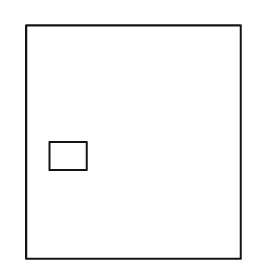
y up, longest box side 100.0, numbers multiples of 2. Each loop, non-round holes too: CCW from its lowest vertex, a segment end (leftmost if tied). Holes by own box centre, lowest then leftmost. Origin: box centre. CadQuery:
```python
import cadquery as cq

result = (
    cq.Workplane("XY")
    .moveTo(-46.0, -50.0)
    .lineTo(46.0, -50.0)
    .lineTo(46.0, 50.0)
    .lineTo(-46.0, 50.0)
    .close()
    .moveTo(-36.0, -12.0)
    .lineTo(-20.0, -12.0)
    .lineTo(-20.0, 0.0)
    .lineTo(-36.0, 0.0)
    .close()
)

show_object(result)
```